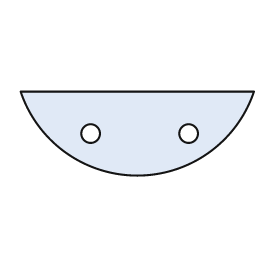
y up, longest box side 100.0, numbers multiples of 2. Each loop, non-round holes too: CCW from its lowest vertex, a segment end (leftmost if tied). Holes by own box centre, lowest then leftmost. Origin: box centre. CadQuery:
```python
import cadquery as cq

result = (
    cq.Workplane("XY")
    .moveTo(-50.0, 18.0)
    .threePointArc((0.0, -18.0), (50.0, 18.0))
    .close()
    .moveTo(-20.0, 0.0)
    .circle(4.0)
    .moveTo(22.0, 0.0)
    .circle(4.0)
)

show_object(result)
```